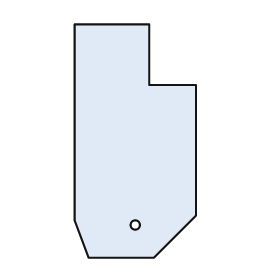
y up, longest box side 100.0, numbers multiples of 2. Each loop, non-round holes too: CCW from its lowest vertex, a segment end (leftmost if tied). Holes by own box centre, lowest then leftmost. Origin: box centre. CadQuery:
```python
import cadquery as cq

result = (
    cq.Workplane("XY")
    .moveTo(-20.0, -50.0)
    .lineTo(8.0, -50.0)
    .lineTo(26.0, -32.0)
    .lineTo(26.0, 24.0)
    .lineTo(6.0, 24.0)
    .lineTo(6.0, 50.0)
    .lineTo(-26.0, 50.0)
    .lineTo(-26.0, -34.0)
    .close()
    .moveTo(0.0, -36.0)
    .circle(2.0)
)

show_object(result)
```